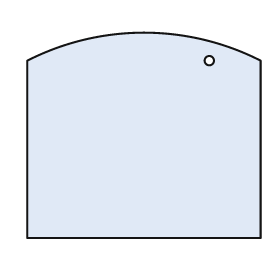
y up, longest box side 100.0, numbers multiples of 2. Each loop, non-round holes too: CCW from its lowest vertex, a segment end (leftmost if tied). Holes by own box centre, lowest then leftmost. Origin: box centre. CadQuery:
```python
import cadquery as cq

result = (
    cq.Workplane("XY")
    .moveTo(-50.0, -44.0)
    .lineTo(50.0, -44.0)
    .lineTo(50.0, 32.0)
    .threePointArc((0.0, 44.0), (-50.0, 32.0))
    .close()
    .moveTo(28.0, 32.0)
    .circle(2.0)
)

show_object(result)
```